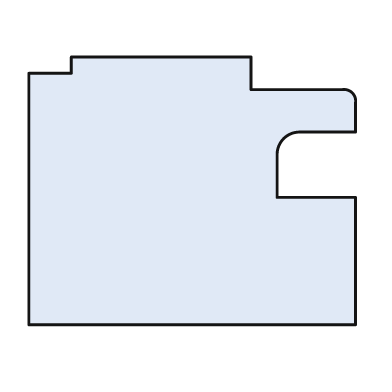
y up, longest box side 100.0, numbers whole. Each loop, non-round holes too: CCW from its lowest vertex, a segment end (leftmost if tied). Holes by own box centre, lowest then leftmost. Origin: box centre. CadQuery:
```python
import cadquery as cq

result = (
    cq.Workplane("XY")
    .moveTo(-50.0, -41.0)
    .lineTo(50.0, -41.0)
    .lineTo(50.0, -2.0)
    .lineTo(26.0, -2.0)
    .lineTo(26.0, 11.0)
    .threePointArc((28.0, 16.0), (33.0, 18.0))
    .lineTo(50.0, 18.0)
    .lineTo(50.0, 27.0)
    .threePointArc((49.0, 30.0), (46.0, 31.0))
    .lineTo(18.0, 31.0)
    .lineTo(18.0, 41.0)
    .lineTo(-37.0, 41.0)
    .lineTo(-37.0, 36.0)
    .lineTo(-50.0, 36.0)
    .close()
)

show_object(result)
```